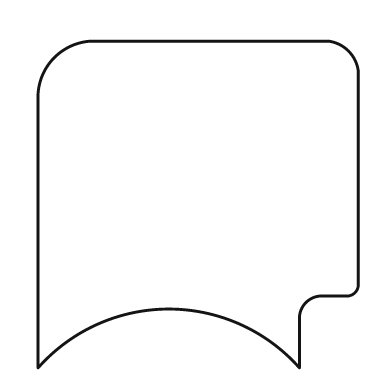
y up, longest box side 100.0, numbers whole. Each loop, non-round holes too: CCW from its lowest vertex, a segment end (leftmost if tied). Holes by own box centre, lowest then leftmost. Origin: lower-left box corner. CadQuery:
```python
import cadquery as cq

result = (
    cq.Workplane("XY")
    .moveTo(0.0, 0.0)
    .threePointArc((40.0, 18.0), (80.0, 0.0))
    .lineTo(80.0, 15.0)
    .threePointArc((82.0, 20.0), (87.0, 22.0))
    .lineTo(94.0, 22.0)
    .threePointArc((97.0, 23.0), (98.0, 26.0))
    .lineTo(98.0, 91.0)
    .threePointArc((95.0, 97.0), (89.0, 100.0))
    .lineTo(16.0, 100.0)
    .threePointArc((5.0, 95.0), (0.0, 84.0))
    .close()
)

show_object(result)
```